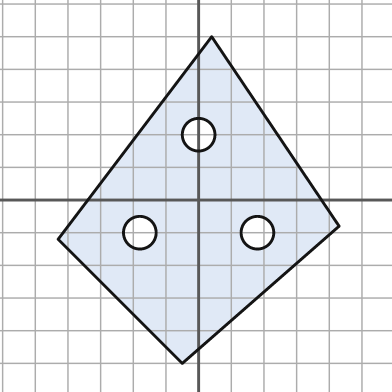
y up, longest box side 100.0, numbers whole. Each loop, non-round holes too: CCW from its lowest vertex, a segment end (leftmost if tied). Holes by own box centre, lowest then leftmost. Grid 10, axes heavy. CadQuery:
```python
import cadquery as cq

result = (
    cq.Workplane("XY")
    .moveTo(-5.0, -50.0)
    .lineTo(43.0, -8.0)
    .lineTo(4.0, 50.0)
    .lineTo(-43.0, -12.0)
    .close()
    .moveTo(-18.0, -10.0)
    .circle(5.0)
    .moveTo(18.0, -10.0)
    .circle(5.0)
    .moveTo(0.0, 20.0)
    .circle(5.0)
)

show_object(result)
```